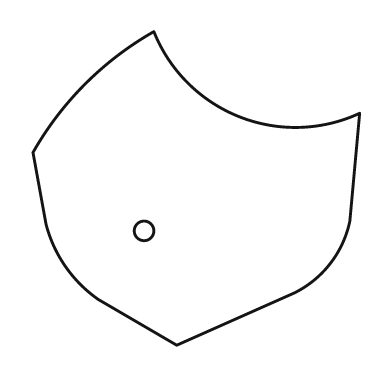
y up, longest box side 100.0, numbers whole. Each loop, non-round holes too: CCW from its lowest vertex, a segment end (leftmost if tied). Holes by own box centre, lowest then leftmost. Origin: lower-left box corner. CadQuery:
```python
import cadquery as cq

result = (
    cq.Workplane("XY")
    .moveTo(44.0, 0.0)
    .lineTo(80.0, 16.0)
    .threePointArc((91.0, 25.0), (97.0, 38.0))
    .lineTo(100.0, 71.0)
    .threePointArc((63.0, 70.0), (37.0, 96.0))
    .threePointArc((16.0, 80.0), (0.0, 59.0))
    .lineTo(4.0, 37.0)
    .threePointArc((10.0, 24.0), (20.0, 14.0))
    .close()
    .moveTo(34.0, 35.0)
    .circle(3.0)
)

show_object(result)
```